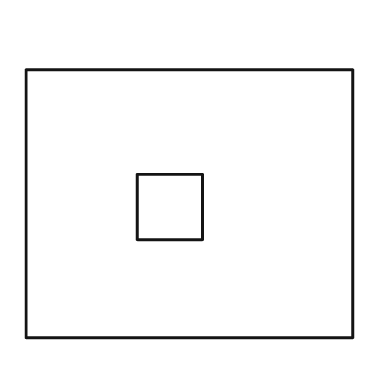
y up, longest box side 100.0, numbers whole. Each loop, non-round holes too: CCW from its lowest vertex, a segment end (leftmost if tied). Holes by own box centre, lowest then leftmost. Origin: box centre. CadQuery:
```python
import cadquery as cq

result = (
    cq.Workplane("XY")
    .moveTo(-50.0, -41.0)
    .lineTo(50.0, -41.0)
    .lineTo(50.0, 41.0)
    .lineTo(-50.0, 41.0)
    .close()
    .moveTo(-16.0, -11.0)
    .lineTo(4.0, -11.0)
    .lineTo(4.0, 9.0)
    .lineTo(-16.0, 9.0)
    .close()
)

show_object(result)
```